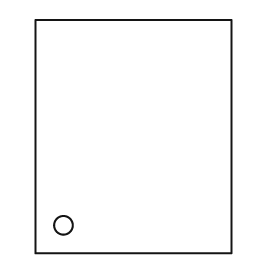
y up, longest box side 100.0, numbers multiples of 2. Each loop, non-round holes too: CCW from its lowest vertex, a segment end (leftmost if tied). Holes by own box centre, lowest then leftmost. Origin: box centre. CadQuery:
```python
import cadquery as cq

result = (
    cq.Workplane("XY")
    .moveTo(-42.0, -50.0)
    .lineTo(42.0, -50.0)
    .lineTo(42.0, 50.0)
    .lineTo(-42.0, 50.0)
    .close()
    .moveTo(-30.0, -38.0)
    .circle(4.0)
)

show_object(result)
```